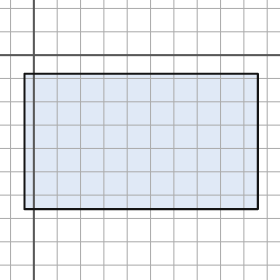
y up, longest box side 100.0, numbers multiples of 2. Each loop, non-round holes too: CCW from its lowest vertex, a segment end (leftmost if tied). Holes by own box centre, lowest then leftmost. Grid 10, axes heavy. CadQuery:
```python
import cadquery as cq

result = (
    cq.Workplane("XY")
    .moveTo(-4.0, -66.0)
    .lineTo(96.0, -66.0)
    .lineTo(96.0, -8.0)
    .lineTo(-4.0, -8.0)
    .close()
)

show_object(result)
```